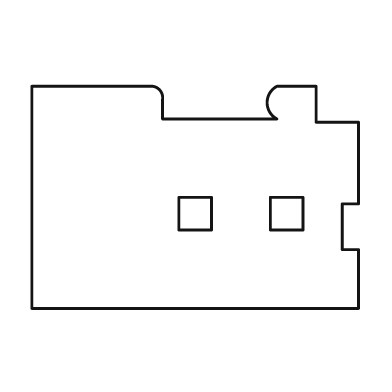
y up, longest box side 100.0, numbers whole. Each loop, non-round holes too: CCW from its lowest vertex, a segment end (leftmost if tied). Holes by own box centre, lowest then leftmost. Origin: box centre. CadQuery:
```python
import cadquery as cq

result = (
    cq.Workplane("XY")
    .moveTo(-50.0, -34.0)
    .lineTo(50.0, -34.0)
    .lineTo(50.0, -16.0)
    .lineTo(45.0, -16.0)
    .lineTo(45.0, -2.0)
    .lineTo(50.0, -2.0)
    .lineTo(50.0, 23.0)
    .lineTo(37.0, 23.0)
    .lineTo(37.0, 34.0)
    .lineTo(25.0, 34.0)
    .threePointArc((22.0, 29.0), (25.0, 24.0))
    .lineTo(-10.0, 24.0)
    .lineTo(-10.0, 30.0)
    .threePointArc((-11.0, 33.0), (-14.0, 34.0))
    .lineTo(-50.0, 34.0)
    .close()
    .moveTo(-5.0, -10.0)
    .lineTo(5.0, -10.0)
    .lineTo(5.0, 0.0)
    .lineTo(-5.0, 0.0)
    .close()
    .moveTo(23.0, -10.0)
    .lineTo(33.0, -10.0)
    .lineTo(33.0, 0.0)
    .lineTo(23.0, 0.0)
    .close()
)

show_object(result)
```